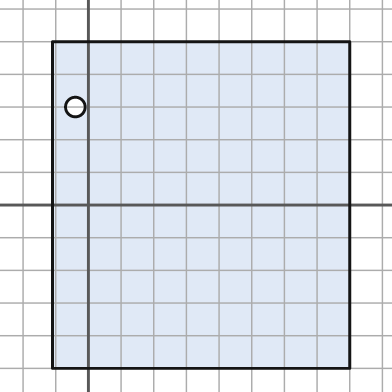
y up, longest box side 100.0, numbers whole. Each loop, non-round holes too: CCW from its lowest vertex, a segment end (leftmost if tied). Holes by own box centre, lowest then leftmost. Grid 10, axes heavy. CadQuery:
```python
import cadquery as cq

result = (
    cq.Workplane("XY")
    .moveTo(-11.0, -50.0)
    .lineTo(80.0, -50.0)
    .lineTo(80.0, 50.0)
    .lineTo(-11.0, 50.0)
    .close()
    .moveTo(-4.0, 30.0)
    .circle(3.0)
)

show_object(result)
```